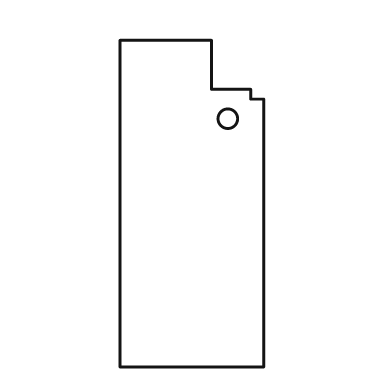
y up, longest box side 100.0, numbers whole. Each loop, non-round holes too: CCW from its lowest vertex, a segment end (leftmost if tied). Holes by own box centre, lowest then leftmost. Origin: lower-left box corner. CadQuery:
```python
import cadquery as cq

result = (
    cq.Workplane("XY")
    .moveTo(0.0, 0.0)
    .lineTo(44.0, 0.0)
    .lineTo(44.0, 82.0)
    .lineTo(40.0, 82.0)
    .lineTo(40.0, 85.0)
    .lineTo(28.0, 85.0)
    .lineTo(28.0, 100.0)
    .lineTo(0.0, 100.0)
    .close()
    .moveTo(33.0, 76.0)
    .circle(3.0)
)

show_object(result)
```